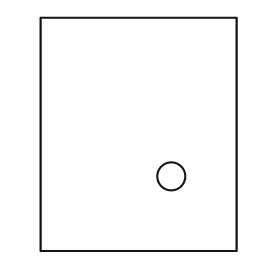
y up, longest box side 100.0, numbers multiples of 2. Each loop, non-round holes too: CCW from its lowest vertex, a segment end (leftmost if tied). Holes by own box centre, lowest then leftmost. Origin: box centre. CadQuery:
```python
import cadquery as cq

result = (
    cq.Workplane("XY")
    .moveTo(-42.0, -50.0)
    .lineTo(42.0, -50.0)
    .lineTo(42.0, 50.0)
    .lineTo(-42.0, 50.0)
    .close()
    .moveTo(14.0, -18.0)
    .circle(6.0)
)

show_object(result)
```